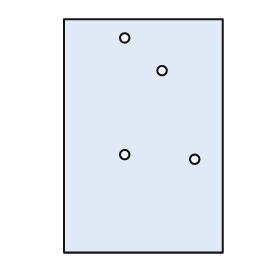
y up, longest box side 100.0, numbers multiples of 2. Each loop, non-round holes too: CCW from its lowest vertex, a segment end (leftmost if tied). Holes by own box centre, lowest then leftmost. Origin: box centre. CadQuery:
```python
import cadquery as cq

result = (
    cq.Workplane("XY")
    .moveTo(-34.0, -50.0)
    .lineTo(34.0, -50.0)
    .lineTo(34.0, 50.0)
    .lineTo(-34.0, 50.0)
    .close()
    .moveTo(22.0, -10.0)
    .circle(2.0)
    .moveTo(-8.0, -8.0)
    .circle(2.0)
    .moveTo(8.0, 28.0)
    .circle(2.0)
    .moveTo(-8.0, 42.0)
    .circle(2.0)
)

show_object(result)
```